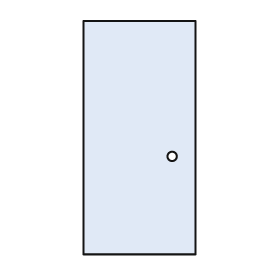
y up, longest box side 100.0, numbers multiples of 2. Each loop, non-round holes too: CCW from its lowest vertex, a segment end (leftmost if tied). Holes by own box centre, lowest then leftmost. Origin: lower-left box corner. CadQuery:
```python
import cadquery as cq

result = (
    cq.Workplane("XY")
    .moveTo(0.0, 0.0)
    .lineTo(48.0, 0.0)
    .lineTo(48.0, 100.0)
    .lineTo(0.0, 100.0)
    .close()
    .moveTo(38.0, 42.0)
    .circle(2.0)
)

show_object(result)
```